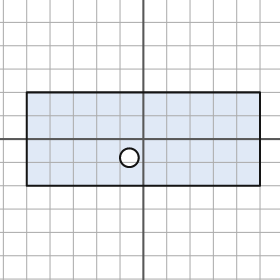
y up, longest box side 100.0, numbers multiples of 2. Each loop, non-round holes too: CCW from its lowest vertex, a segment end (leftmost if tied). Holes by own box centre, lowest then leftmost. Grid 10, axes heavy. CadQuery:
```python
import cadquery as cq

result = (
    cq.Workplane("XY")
    .moveTo(-50.0, -20.0)
    .lineTo(50.0, -20.0)
    .lineTo(50.0, 20.0)
    .lineTo(-50.0, 20.0)
    .close()
    .moveTo(-6.0, -8.0)
    .circle(4.0)
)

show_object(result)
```